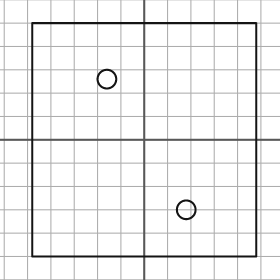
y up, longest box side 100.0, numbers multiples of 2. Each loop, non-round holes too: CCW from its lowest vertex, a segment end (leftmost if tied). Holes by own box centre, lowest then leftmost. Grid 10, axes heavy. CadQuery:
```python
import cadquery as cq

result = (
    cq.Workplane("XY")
    .moveTo(-48.0, -50.0)
    .lineTo(48.0, -50.0)
    .lineTo(48.0, 50.0)
    .lineTo(-48.0, 50.0)
    .close()
    .moveTo(18.0, -30.0)
    .circle(4.0)
    .moveTo(-16.0, 26.0)
    .circle(4.0)
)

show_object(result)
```